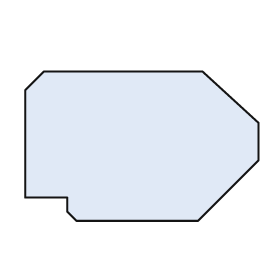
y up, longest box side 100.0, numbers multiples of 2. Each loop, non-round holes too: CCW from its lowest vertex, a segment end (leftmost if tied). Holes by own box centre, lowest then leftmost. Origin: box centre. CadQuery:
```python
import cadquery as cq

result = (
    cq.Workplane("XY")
    .moveTo(-28.0, -32.0)
    .lineTo(24.0, -32.0)
    .lineTo(50.0, -6.0)
    .lineTo(50.0, 10.0)
    .lineTo(26.0, 32.0)
    .lineTo(-42.0, 32.0)
    .lineTo(-50.0, 24.0)
    .lineTo(-50.0, -22.0)
    .lineTo(-32.0, -22.0)
    .lineTo(-32.0, -28.0)
    .close()
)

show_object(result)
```